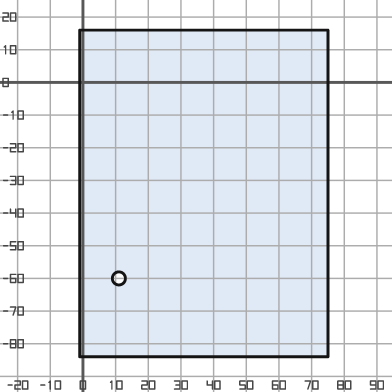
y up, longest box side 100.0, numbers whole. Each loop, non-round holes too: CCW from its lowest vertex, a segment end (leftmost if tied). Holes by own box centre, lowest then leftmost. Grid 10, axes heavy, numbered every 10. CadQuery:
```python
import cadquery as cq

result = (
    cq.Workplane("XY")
    .moveTo(-1.0, -84.0)
    .lineTo(75.0, -84.0)
    .lineTo(75.0, 16.0)
    .lineTo(-1.0, 16.0)
    .close()
    .moveTo(11.0, -60.0)
    .circle(2.0)
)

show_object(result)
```